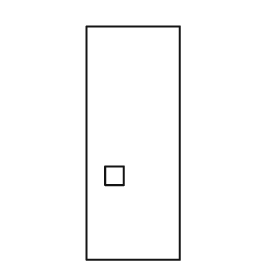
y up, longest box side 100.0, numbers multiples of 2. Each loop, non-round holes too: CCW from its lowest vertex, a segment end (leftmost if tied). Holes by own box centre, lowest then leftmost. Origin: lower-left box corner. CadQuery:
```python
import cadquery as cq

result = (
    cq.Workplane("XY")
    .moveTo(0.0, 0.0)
    .lineTo(40.0, 0.0)
    .lineTo(40.0, 100.0)
    .lineTo(0.0, 100.0)
    .close()
    .moveTo(8.0, 32.0)
    .lineTo(16.0, 32.0)
    .lineTo(16.0, 40.0)
    .lineTo(8.0, 40.0)
    .close()
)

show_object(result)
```